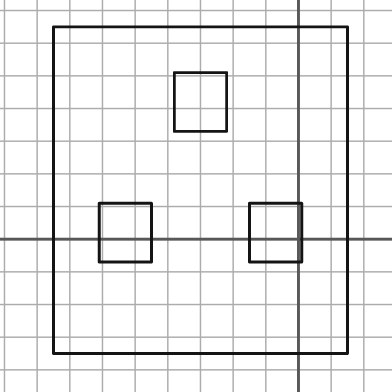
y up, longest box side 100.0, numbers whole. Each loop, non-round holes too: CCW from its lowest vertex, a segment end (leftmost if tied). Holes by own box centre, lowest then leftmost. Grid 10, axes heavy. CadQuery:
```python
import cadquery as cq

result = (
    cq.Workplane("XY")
    .moveTo(-75.0, -35.0)
    .lineTo(15.0, -35.0)
    .lineTo(15.0, 65.0)
    .lineTo(-75.0, 65.0)
    .close()
    .moveTo(-61.0, -7.0)
    .lineTo(-45.0, -7.0)
    .lineTo(-45.0, 11.0)
    .lineTo(-61.0, 11.0)
    .close()
    .moveTo(-15.0, -7.0)
    .lineTo(1.0, -7.0)
    .lineTo(1.0, 11.0)
    .lineTo(-15.0, 11.0)
    .close()
    .moveTo(-38.0, 33.0)
    .lineTo(-22.0, 33.0)
    .lineTo(-22.0, 51.0)
    .lineTo(-38.0, 51.0)
    .close()
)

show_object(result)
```